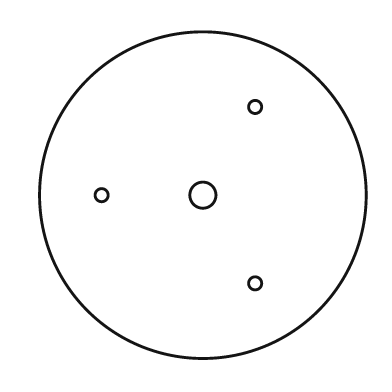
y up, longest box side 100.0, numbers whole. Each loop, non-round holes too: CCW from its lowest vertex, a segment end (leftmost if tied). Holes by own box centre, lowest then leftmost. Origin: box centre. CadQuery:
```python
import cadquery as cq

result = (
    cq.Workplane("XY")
    .moveTo(0.0, 0.0)
    .circle(50.0)
    .moveTo(16.0, -27.0)
    .circle(2.0)
    .moveTo(-31.0, 0.0)
    .circle(2.0)
    .moveTo(0.0, 0.0)
    .circle(4.0)
    .moveTo(16.0, 27.0)
    .circle(2.0)
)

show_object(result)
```